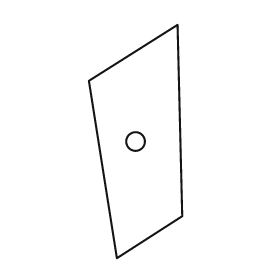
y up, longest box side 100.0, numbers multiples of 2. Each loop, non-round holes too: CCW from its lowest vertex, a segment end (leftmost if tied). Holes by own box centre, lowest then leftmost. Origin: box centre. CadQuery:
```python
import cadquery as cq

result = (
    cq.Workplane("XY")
    .moveTo(-8.0, -50.0)
    .lineTo(20.0, -32.0)
    .lineTo(18.0, 50.0)
    .lineTo(-20.0, 26.0)
    .close()
    .moveTo(0.0, 0.0)
    .circle(4.0)
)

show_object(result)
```